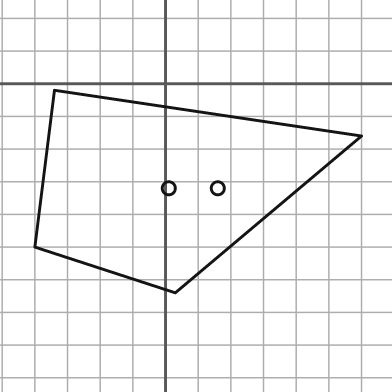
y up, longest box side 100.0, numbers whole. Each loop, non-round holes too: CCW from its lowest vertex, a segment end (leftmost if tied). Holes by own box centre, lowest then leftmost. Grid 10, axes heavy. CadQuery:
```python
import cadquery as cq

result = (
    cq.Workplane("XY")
    .moveTo(3.0, -64.0)
    .lineTo(60.0, -16.0)
    .lineTo(-34.0, -2.0)
    .lineTo(-40.0, -50.0)
    .close()
    .moveTo(1.0, -32.0)
    .circle(2.0)
    .moveTo(16.0, -32.0)
    .circle(2.0)
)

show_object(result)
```